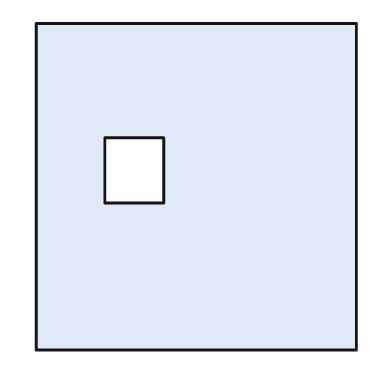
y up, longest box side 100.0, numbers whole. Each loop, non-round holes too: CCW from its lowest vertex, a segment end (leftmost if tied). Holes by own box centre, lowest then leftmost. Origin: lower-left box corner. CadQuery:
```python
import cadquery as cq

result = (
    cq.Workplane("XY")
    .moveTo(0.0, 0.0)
    .lineTo(98.0, 0.0)
    .lineTo(98.0, 100.0)
    .lineTo(0.0, 100.0)
    .close()
    .moveTo(21.0, 45.0)
    .lineTo(39.0, 45.0)
    .lineTo(39.0, 65.0)
    .lineTo(21.0, 65.0)
    .close()
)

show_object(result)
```